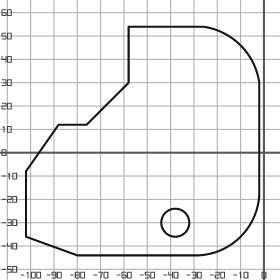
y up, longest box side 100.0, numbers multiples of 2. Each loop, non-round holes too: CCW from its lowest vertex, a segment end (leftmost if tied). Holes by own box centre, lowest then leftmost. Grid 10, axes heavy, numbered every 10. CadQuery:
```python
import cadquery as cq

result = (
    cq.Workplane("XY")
    .moveTo(-80.0, -44.0)
    .lineTo(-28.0, -44.0)
    .threePointArc((-10.0, -36.0), (-2.0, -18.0))
    .lineTo(-2.0, 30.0)
    .threePointArc((-10.0, 46.0), (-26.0, 54.0))
    .lineTo(-58.0, 54.0)
    .lineTo(-58.0, 30.0)
    .lineTo(-76.0, 12.0)
    .lineTo(-88.0, 12.0)
    .lineTo(-102.0, -8.0)
    .lineTo(-102.0, -36.0)
    .close()
    .moveTo(-38.0, -30.0)
    .circle(6.0)
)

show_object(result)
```